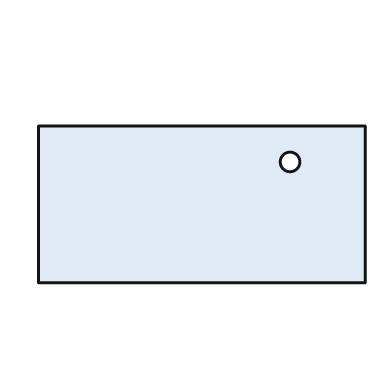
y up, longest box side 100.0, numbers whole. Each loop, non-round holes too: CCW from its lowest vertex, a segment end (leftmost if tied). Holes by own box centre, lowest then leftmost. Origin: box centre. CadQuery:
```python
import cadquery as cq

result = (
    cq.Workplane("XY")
    .moveTo(-50.0, -24.0)
    .lineTo(50.0, -24.0)
    .lineTo(50.0, 24.0)
    .lineTo(-50.0, 24.0)
    .close()
    .moveTo(27.0, 13.0)
    .circle(3.0)
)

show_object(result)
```